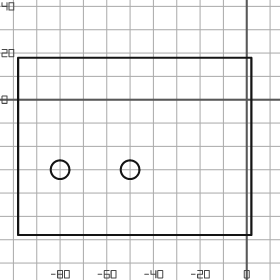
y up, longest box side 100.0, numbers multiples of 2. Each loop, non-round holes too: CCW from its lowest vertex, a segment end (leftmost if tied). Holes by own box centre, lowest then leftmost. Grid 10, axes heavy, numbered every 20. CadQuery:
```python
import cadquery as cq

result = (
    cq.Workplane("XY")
    .moveTo(-98.0, -58.0)
    .lineTo(2.0, -58.0)
    .lineTo(2.0, 18.0)
    .lineTo(-98.0, 18.0)
    .close()
    .moveTo(-80.0, -30.0)
    .circle(4.0)
    .moveTo(-50.0, -30.0)
    .circle(4.0)
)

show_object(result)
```